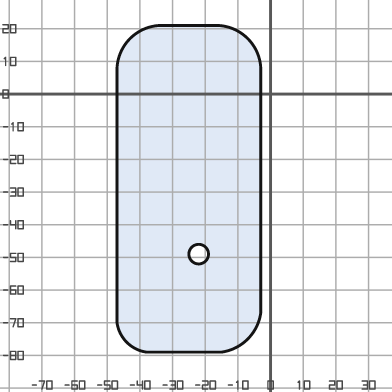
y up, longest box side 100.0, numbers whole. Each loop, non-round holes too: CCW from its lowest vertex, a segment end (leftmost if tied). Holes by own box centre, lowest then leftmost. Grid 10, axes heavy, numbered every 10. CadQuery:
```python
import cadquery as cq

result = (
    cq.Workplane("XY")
    .moveTo(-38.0, -79.0)
    .lineTo(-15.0, -79.0)
    .threePointArc((-7.0, -75.0), (-3.0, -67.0))
    .lineTo(-3.0, 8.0)
    .threePointArc((-7.0, 17.0), (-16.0, 21.0))
    .lineTo(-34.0, 21.0)
    .threePointArc((-43.0, 17.0), (-47.0, 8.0))
    .lineTo(-47.0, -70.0)
    .threePointArc((-44.0, -76.0), (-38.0, -79.0))
    .close()
    .moveTo(-22.0, -49.0)
    .circle(3.0)
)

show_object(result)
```